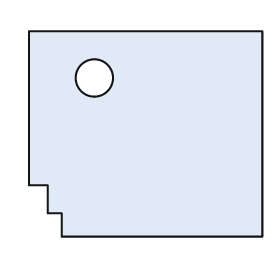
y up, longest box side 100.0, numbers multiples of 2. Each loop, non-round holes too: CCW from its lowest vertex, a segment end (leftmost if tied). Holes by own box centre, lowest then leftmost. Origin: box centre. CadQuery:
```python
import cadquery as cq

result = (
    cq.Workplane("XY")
    .moveTo(-36.0, -44.0)
    .lineTo(50.0, -44.0)
    .lineTo(50.0, 44.0)
    .lineTo(-50.0, 44.0)
    .lineTo(-50.0, -22.0)
    .lineTo(-42.0, -22.0)
    .lineTo(-42.0, -34.0)
    .lineTo(-36.0, -34.0)
    .close()
    .moveTo(-22.0, 24.0)
    .circle(8.0)
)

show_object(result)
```